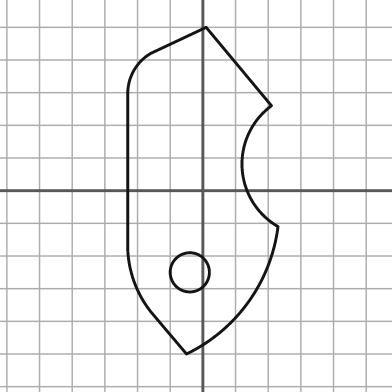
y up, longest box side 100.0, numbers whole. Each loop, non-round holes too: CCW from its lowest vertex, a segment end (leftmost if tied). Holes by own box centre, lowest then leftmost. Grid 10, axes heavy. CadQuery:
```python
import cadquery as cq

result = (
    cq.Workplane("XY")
    .moveTo(-5.0, -50.0)
    .threePointArc((14.0, -34.0), (23.0, -11.0))
    .threePointArc((12.0, 7.0), (21.0, 26.0))
    .lineTo(1.0, 50.0)
    .lineTo(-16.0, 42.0)
    .threePointArc((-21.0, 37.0), (-23.0, 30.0))
    .lineTo(-23.0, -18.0)
    .threePointArc((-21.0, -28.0), (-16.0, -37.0))
    .close()
    .moveTo(-4.0, -25.0)
    .circle(6.0)
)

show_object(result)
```